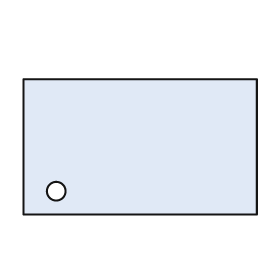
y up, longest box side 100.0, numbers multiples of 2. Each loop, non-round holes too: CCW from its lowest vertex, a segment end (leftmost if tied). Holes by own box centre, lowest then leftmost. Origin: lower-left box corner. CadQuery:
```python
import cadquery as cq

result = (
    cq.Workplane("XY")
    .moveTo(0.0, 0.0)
    .lineTo(100.0, 0.0)
    .lineTo(100.0, 58.0)
    .lineTo(0.0, 58.0)
    .close()
    .moveTo(14.0, 10.0)
    .circle(4.0)
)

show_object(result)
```